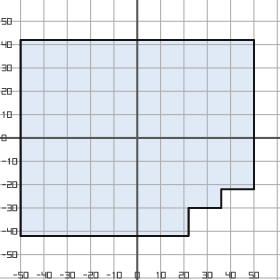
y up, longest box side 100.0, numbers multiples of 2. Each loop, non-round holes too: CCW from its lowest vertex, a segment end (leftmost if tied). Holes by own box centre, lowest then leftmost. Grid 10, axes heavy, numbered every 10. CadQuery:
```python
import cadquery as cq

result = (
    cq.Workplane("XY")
    .moveTo(-50.0, -42.0)
    .lineTo(22.0, -42.0)
    .lineTo(22.0, -30.0)
    .lineTo(36.0, -30.0)
    .lineTo(36.0, -22.0)
    .lineTo(50.0, -22.0)
    .lineTo(50.0, 42.0)
    .lineTo(-50.0, 42.0)
    .close()
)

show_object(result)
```